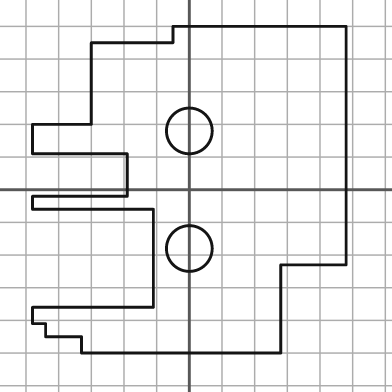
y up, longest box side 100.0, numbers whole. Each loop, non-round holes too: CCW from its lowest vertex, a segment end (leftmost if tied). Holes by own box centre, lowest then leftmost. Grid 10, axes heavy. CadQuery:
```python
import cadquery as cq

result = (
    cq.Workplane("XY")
    .moveTo(-33.0, -50.0)
    .lineTo(28.0, -50.0)
    .lineTo(28.0, -23.0)
    .lineTo(48.0, -23.0)
    .lineTo(48.0, 50.0)
    .lineTo(-5.0, 50.0)
    .lineTo(-5.0, 45.0)
    .lineTo(-30.0, 45.0)
    .lineTo(-30.0, 20.0)
    .lineTo(-48.0, 20.0)
    .lineTo(-48.0, 11.0)
    .lineTo(-19.0, 11.0)
    .lineTo(-19.0, -2.0)
    .lineTo(-48.0, -2.0)
    .lineTo(-48.0, -6.0)
    .lineTo(-11.0, -6.0)
    .lineTo(-11.0, -36.0)
    .lineTo(-48.0, -36.0)
    .lineTo(-48.0, -41.0)
    .lineTo(-44.0, -41.0)
    .lineTo(-44.0, -45.0)
    .lineTo(-33.0, -45.0)
    .close()
    .moveTo(0.0, -18.0)
    .circle(7.0)
    .moveTo(0.0, 18.0)
    .circle(7.0)
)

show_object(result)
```